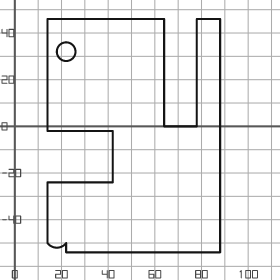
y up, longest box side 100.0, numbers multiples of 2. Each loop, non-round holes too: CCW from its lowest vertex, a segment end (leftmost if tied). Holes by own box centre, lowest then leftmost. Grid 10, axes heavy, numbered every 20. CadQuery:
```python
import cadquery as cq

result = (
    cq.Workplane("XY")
    .moveTo(22.0, -54.0)
    .lineTo(88.0, -54.0)
    .lineTo(88.0, 46.0)
    .lineTo(78.0, 46.0)
    .lineTo(78.0, 0.0)
    .lineTo(64.0, 0.0)
    .lineTo(64.0, 46.0)
    .lineTo(14.0, 46.0)
    .lineTo(14.0, -2.0)
    .lineTo(42.0, -2.0)
    .lineTo(42.0, -24.0)
    .lineTo(14.0, -24.0)
    .lineTo(14.0, -50.0)
    .threePointArc((18.0, -52.0), (22.0, -50.0))
    .close()
    .moveTo(22.0, 32.0)
    .circle(4.0)
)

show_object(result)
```